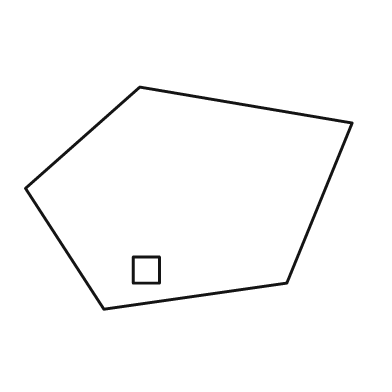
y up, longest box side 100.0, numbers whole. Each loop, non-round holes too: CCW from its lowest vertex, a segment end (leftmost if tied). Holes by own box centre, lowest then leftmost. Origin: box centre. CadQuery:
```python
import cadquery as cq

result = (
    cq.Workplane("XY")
    .moveTo(-26.0, -34.0)
    .lineTo(30.0, -26.0)
    .lineTo(50.0, 23.0)
    .lineTo(-15.0, 34.0)
    .lineTo(-50.0, 3.0)
    .close()
    .moveTo(-17.0, -26.0)
    .lineTo(-9.0, -26.0)
    .lineTo(-9.0, -18.0)
    .lineTo(-17.0, -18.0)
    .close()
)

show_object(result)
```